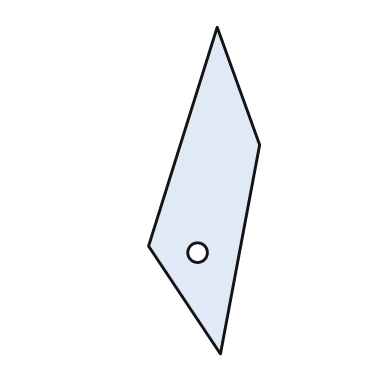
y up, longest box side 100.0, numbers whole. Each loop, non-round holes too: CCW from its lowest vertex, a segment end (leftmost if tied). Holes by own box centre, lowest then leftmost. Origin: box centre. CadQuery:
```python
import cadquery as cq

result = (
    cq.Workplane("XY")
    .moveTo(5.0, -50.0)
    .lineTo(17.0, 14.0)
    .lineTo(4.0, 50.0)
    .lineTo(-17.0, -17.0)
    .close()
    .moveTo(-2.0, -19.0)
    .circle(3.0)
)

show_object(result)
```